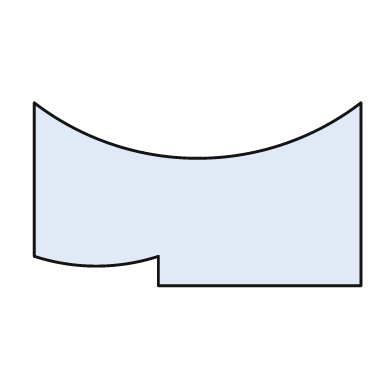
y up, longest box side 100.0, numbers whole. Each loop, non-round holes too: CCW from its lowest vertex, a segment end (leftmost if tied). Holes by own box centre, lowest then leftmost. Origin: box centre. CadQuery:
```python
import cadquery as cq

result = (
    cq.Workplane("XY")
    .moveTo(-12.0, -28.0)
    .lineTo(50.0, -28.0)
    .lineTo(50.0, 28.0)
    .threePointArc((0.0, 11.0), (-50.0, 28.0))
    .lineTo(-50.0, -19.0)
    .threePointArc((-31.0, -22.0), (-12.0, -19.0))
    .close()
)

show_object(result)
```